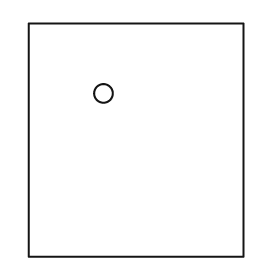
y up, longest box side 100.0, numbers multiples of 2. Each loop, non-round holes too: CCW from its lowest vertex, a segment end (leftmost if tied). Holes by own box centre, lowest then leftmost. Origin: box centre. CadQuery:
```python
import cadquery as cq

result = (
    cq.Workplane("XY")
    .moveTo(-46.0, -50.0)
    .lineTo(46.0, -50.0)
    .lineTo(46.0, 50.0)
    .lineTo(-46.0, 50.0)
    .close()
    .moveTo(-14.0, 20.0)
    .circle(4.0)
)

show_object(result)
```